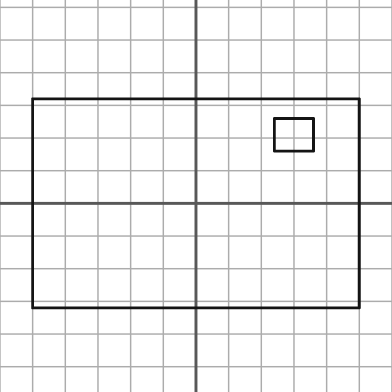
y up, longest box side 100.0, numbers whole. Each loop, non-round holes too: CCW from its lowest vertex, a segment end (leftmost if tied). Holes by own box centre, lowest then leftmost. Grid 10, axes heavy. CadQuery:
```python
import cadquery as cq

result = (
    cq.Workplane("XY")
    .moveTo(-50.0, -32.0)
    .lineTo(50.0, -32.0)
    .lineTo(50.0, 32.0)
    .lineTo(-50.0, 32.0)
    .close()
    .moveTo(24.0, 16.0)
    .lineTo(36.0, 16.0)
    .lineTo(36.0, 26.0)
    .lineTo(24.0, 26.0)
    .close()
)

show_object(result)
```